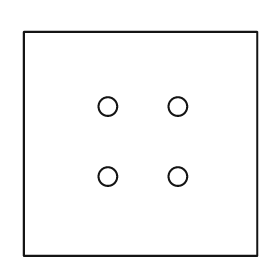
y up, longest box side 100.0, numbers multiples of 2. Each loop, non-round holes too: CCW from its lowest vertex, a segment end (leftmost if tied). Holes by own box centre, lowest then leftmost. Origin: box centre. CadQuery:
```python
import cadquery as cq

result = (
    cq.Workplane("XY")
    .moveTo(-50.0, -48.0)
    .lineTo(50.0, -48.0)
    .lineTo(50.0, 48.0)
    .lineTo(-50.0, 48.0)
    .close()
    .moveTo(-14.0, -14.0)
    .circle(4.0)
    .moveTo(16.0, -14.0)
    .circle(4.0)
    .moveTo(-14.0, 16.0)
    .circle(4.0)
    .moveTo(16.0, 16.0)
    .circle(4.0)
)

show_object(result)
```